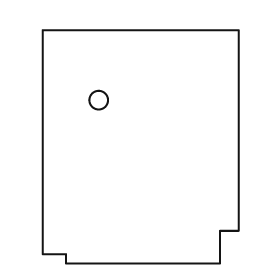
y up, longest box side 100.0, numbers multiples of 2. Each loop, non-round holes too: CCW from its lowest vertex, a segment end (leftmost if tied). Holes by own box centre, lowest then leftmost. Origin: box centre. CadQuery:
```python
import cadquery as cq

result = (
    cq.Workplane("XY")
    .moveTo(-32.0, -50.0)
    .lineTo(34.0, -50.0)
    .lineTo(34.0, -36.0)
    .lineTo(42.0, -36.0)
    .lineTo(42.0, 50.0)
    .lineTo(-42.0, 50.0)
    .lineTo(-42.0, -46.0)
    .lineTo(-32.0, -46.0)
    .close()
    .moveTo(-18.0, 20.0)
    .circle(4.0)
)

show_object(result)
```